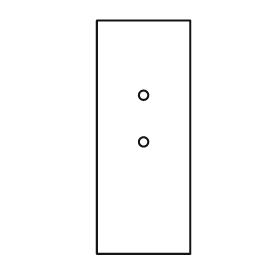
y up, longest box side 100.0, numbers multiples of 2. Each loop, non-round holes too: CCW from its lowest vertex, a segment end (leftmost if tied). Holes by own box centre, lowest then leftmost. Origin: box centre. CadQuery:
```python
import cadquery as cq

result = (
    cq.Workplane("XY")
    .moveTo(-20.0, -50.0)
    .lineTo(20.0, -50.0)
    .lineTo(20.0, 50.0)
    .lineTo(-20.0, 50.0)
    .close()
    .moveTo(0.0, -2.0)
    .circle(2.0)
    .moveTo(0.0, 18.0)
    .circle(2.0)
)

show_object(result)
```